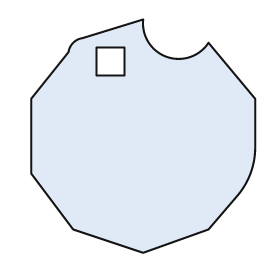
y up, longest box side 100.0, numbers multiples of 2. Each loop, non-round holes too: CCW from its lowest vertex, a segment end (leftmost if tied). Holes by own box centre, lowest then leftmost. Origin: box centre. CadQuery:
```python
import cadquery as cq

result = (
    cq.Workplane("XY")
    .moveTo(0.0, -50.0)
    .lineTo(28.0, -40.0)
    .lineTo(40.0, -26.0)
    .threePointArc((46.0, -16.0), (48.0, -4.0))
    .lineTo(48.0, 16.0)
    .lineTo(28.0, 40.0)
    .threePointArc((10.0, 34.0), (0.0, 50.0))
    .lineTo(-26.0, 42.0)
    .threePointArc((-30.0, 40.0), (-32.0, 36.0))
    .lineTo(-48.0, 16.0)
    .lineTo(-48.0, -16.0)
    .lineTo(-30.0, -40.0)
    .close()
    .moveTo(-20.0, 26.0)
    .lineTo(-8.0, 26.0)
    .lineTo(-8.0, 38.0)
    .lineTo(-20.0, 38.0)
    .close()
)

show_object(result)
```